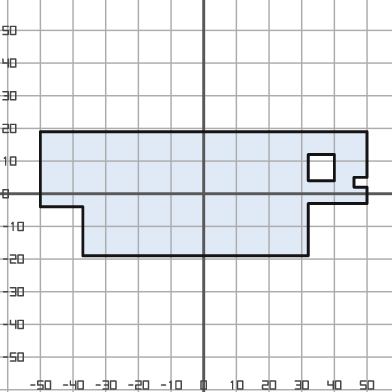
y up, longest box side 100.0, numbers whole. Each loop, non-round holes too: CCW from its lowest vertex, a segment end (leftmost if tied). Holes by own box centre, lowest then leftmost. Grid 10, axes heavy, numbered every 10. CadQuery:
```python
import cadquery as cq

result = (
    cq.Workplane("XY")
    .moveTo(-37.0, -19.0)
    .lineTo(32.0, -19.0)
    .lineTo(32.0, -3.0)
    .lineTo(50.0, -3.0)
    .lineTo(50.0, 2.0)
    .lineTo(46.0, 2.0)
    .lineTo(46.0, 5.0)
    .lineTo(50.0, 5.0)
    .lineTo(50.0, 19.0)
    .lineTo(-50.0, 19.0)
    .lineTo(-50.0, -4.0)
    .lineTo(-37.0, -4.0)
    .close()
    .moveTo(32.0, 4.0)
    .lineTo(40.0, 4.0)
    .lineTo(40.0, 12.0)
    .lineTo(32.0, 12.0)
    .close()
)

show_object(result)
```